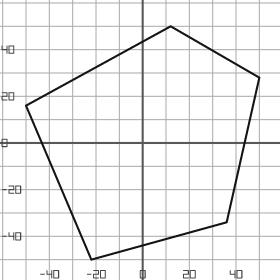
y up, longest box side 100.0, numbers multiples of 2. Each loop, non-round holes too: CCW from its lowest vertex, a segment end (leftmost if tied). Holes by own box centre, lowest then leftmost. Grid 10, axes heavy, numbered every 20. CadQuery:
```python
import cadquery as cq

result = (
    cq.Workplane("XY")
    .moveTo(-22.0, -50.0)
    .lineTo(36.0, -34.0)
    .lineTo(50.0, 28.0)
    .lineTo(12.0, 50.0)
    .lineTo(-50.0, 16.0)
    .close()
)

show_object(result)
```